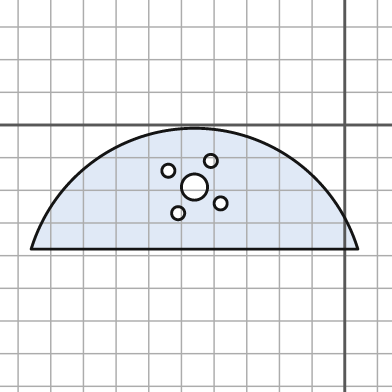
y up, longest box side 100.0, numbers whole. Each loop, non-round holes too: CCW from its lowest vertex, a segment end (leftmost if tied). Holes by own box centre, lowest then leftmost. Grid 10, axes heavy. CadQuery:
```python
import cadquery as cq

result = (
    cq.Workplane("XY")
    .moveTo(-96.0, -38.0)
    .lineTo(4.0, -38.0)
    .threePointArc((-46.0, -1.0), (-96.0, -38.0))
    .close()
    .moveTo(-51.0, -27.0)
    .circle(2.0)
    .moveTo(-38.0, -24.0)
    .circle(2.0)
    .moveTo(-46.0, -19.0)
    .circle(4.0)
    .moveTo(-54.0, -14.0)
    .circle(2.0)
    .moveTo(-41.0, -11.0)
    .circle(2.0)
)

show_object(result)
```